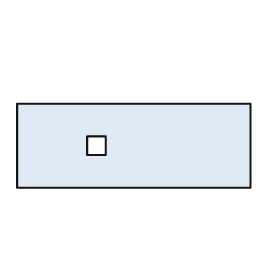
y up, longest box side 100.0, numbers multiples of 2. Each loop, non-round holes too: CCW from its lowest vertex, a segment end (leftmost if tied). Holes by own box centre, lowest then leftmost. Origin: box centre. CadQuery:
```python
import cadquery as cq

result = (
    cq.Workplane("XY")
    .moveTo(-50.0, -18.0)
    .lineTo(50.0, -18.0)
    .lineTo(50.0, 18.0)
    .lineTo(-50.0, 18.0)
    .close()
    .moveTo(-20.0, -4.0)
    .lineTo(-12.0, -4.0)
    .lineTo(-12.0, 4.0)
    .lineTo(-20.0, 4.0)
    .close()
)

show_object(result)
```